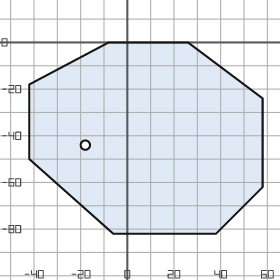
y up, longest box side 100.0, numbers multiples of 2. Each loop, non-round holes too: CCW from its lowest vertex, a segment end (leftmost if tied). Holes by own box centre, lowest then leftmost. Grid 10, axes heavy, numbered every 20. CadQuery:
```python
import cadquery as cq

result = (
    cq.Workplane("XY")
    .moveTo(-6.0, -82.0)
    .lineTo(38.0, -82.0)
    .lineTo(58.0, -62.0)
    .lineTo(58.0, -24.0)
    .lineTo(26.0, 0.0)
    .lineTo(-8.0, 0.0)
    .lineTo(-42.0, -18.0)
    .lineTo(-42.0, -50.0)
    .close()
    .moveTo(-18.0, -44.0)
    .circle(2.0)
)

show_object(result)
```